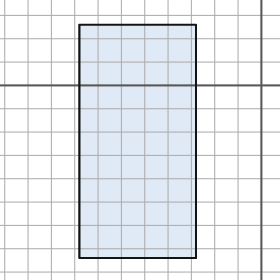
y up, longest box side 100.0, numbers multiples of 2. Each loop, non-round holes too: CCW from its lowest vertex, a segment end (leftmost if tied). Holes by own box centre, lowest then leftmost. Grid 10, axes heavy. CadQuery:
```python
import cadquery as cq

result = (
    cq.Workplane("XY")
    .moveTo(-78.0, -74.0)
    .lineTo(-28.0, -74.0)
    .lineTo(-28.0, 26.0)
    .lineTo(-78.0, 26.0)
    .close()
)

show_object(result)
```